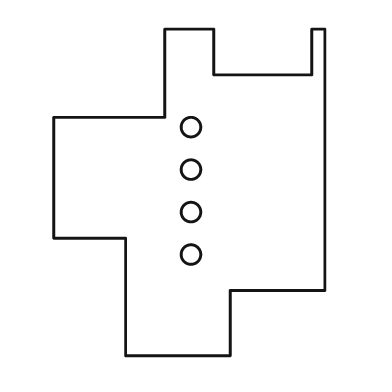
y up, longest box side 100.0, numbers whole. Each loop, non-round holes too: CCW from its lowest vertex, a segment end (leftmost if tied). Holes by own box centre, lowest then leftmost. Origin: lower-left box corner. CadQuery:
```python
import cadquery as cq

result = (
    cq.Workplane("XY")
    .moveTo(22.0, 0.0)
    .lineTo(54.0, 0.0)
    .lineTo(54.0, 20.0)
    .lineTo(83.0, 20.0)
    .lineTo(83.0, 100.0)
    .lineTo(79.0, 100.0)
    .lineTo(79.0, 86.0)
    .lineTo(49.0, 86.0)
    .lineTo(49.0, 100.0)
    .lineTo(34.0, 100.0)
    .lineTo(34.0, 73.0)
    .lineTo(0.0, 73.0)
    .lineTo(0.0, 36.0)
    .lineTo(22.0, 36.0)
    .close()
    .moveTo(42.0, 31.0)
    .circle(3.0)
    .moveTo(42.0, 44.0)
    .circle(3.0)
    .moveTo(42.0, 57.0)
    .circle(3.0)
    .moveTo(42.0, 70.0)
    .circle(3.0)
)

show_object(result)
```